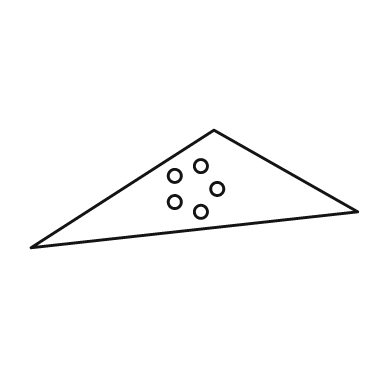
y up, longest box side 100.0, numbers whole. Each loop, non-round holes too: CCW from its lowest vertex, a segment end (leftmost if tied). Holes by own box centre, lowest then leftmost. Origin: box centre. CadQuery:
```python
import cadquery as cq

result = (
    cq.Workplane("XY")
    .moveTo(-50.0, -18.0)
    .lineTo(50.0, -7.0)
    .lineTo(6.0, 18.0)
    .close()
    .moveTo(2.0, -7.0)
    .circle(2.0)
    .moveTo(-6.0, -4.0)
    .circle(2.0)
    .moveTo(7.0, 0.0)
    .circle(2.0)
    .moveTo(-6.0, 4.0)
    .circle(2.0)
    .moveTo(2.0, 7.0)
    .circle(2.0)
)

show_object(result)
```